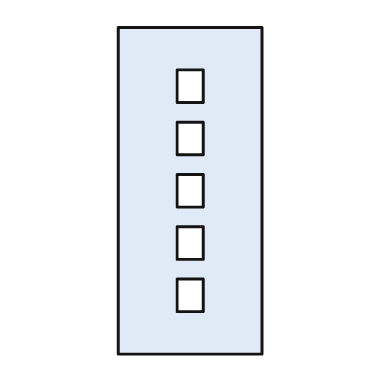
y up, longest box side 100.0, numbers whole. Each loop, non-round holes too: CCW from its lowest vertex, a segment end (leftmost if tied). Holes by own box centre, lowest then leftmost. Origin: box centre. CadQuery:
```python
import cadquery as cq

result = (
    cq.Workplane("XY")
    .moveTo(-22.0, -50.0)
    .lineTo(22.0, -50.0)
    .lineTo(22.0, 50.0)
    .lineTo(-22.0, 50.0)
    .close()
    .moveTo(-4.0, -37.0)
    .lineTo(4.0, -37.0)
    .lineTo(4.0, -27.0)
    .lineTo(-4.0, -27.0)
    .close()
    .moveTo(-4.0, -21.0)
    .lineTo(4.0, -21.0)
    .lineTo(4.0, -11.0)
    .lineTo(-4.0, -11.0)
    .close()
    .moveTo(-4.0, -5.0)
    .lineTo(4.0, -5.0)
    .lineTo(4.0, 5.0)
    .lineTo(-4.0, 5.0)
    .close()
    .moveTo(-4.0, 11.0)
    .lineTo(4.0, 11.0)
    .lineTo(4.0, 21.0)
    .lineTo(-4.0, 21.0)
    .close()
    .moveTo(-4.0, 27.0)
    .lineTo(4.0, 27.0)
    .lineTo(4.0, 37.0)
    .lineTo(-4.0, 37.0)
    .close()
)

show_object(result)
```